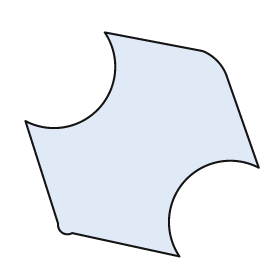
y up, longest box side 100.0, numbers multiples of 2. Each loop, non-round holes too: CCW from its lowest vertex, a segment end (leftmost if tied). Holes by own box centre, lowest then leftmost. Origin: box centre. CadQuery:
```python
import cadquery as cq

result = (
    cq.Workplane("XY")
    .moveTo(16.0, -48.0)
    .threePointArc((18.0, -16.0), (50.0, -10.0))
    .lineTo(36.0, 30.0)
    .threePointArc((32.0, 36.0), (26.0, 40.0))
    .lineTo(-16.0, 48.0)
    .threePointArc((-18.0, 16.0), (-50.0, 10.0))
    .lineTo(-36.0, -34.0)
    .threePointArc((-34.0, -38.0), (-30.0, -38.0))
    .close()
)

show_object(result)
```